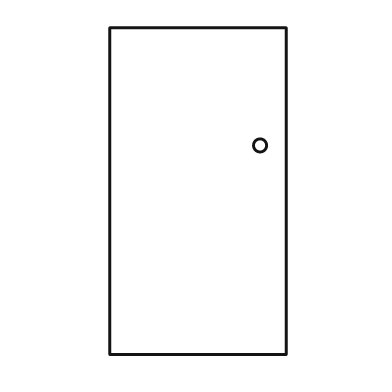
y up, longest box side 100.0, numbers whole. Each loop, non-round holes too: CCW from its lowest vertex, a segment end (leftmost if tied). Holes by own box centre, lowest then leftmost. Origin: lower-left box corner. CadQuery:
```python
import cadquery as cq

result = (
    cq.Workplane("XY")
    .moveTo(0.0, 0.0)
    .lineTo(54.0, 0.0)
    .lineTo(54.0, 100.0)
    .lineTo(0.0, 100.0)
    .close()
    .moveTo(46.0, 64.0)
    .circle(2.0)
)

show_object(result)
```